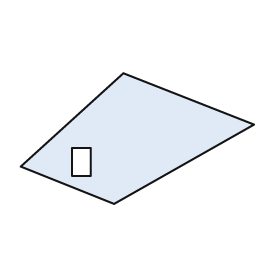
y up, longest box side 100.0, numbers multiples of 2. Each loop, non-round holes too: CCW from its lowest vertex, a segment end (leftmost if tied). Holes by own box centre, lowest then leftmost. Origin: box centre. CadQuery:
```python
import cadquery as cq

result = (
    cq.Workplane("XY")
    .moveTo(-10.0, -28.0)
    .lineTo(50.0, 6.0)
    .lineTo(-6.0, 28.0)
    .lineTo(-50.0, -12.0)
    .close()
    .moveTo(-28.0, -16.0)
    .lineTo(-20.0, -16.0)
    .lineTo(-20.0, -4.0)
    .lineTo(-28.0, -4.0)
    .close()
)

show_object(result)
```